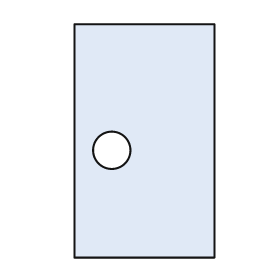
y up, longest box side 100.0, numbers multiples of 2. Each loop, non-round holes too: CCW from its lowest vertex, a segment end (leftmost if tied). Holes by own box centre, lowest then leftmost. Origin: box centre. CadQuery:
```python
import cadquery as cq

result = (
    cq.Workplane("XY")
    .moveTo(-30.0, -50.0)
    .lineTo(30.0, -50.0)
    .lineTo(30.0, 50.0)
    .lineTo(-30.0, 50.0)
    .close()
    .moveTo(-14.0, -4.0)
    .circle(8.0)
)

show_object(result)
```